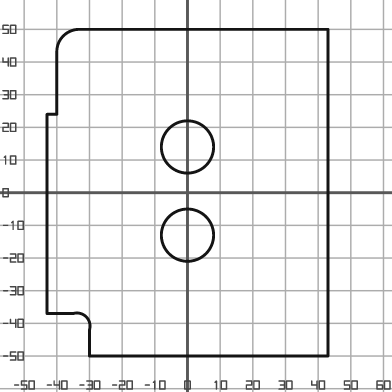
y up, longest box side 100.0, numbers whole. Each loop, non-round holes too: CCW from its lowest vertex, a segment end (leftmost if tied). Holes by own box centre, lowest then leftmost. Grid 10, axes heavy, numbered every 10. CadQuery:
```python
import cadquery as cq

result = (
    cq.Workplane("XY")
    .moveTo(-30.0, -50.0)
    .lineTo(43.0, -50.0)
    .lineTo(43.0, 50.0)
    .lineTo(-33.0, 50.0)
    .threePointArc((-38.0, 48.0), (-40.0, 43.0))
    .lineTo(-40.0, 24.0)
    .lineTo(-43.0, 24.0)
    .lineTo(-43.0, -37.0)
    .lineTo(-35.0, -37.0)
    .threePointArc((-31.0, -38.0), (-30.0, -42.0))
    .close()
    .moveTo(0.0, -13.0)
    .circle(8.0)
    .moveTo(0.0, 14.0)
    .circle(8.0)
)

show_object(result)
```